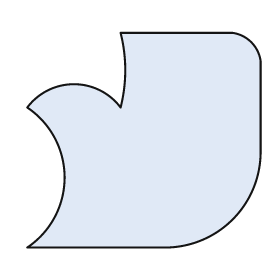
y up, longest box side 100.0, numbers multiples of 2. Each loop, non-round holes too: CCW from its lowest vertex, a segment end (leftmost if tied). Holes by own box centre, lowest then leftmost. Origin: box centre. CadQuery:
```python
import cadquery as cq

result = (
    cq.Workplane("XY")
    .moveTo(-50.0, -46.0)
    .lineTo(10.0, -46.0)
    .threePointArc((38.0, -34.0), (50.0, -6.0))
    .lineTo(50.0, 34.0)
    .threePointArc((46.0, 42.0), (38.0, 46.0))
    .lineTo(-10.0, 46.0)
    .threePointArc((-8.0, 30.0), (-10.0, 14.0))
    .threePointArc((-30.0, 24.0), (-50.0, 14.0))
    .threePointArc((-34.0, -16.0), (-50.0, -46.0))
    .close()
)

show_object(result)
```